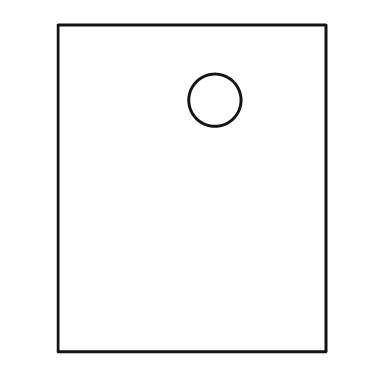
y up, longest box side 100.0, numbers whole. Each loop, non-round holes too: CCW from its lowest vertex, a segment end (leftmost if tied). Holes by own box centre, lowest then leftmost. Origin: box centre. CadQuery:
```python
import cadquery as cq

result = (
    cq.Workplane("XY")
    .moveTo(-41.0, -50.0)
    .lineTo(41.0, -50.0)
    .lineTo(41.0, 50.0)
    .lineTo(-41.0, 50.0)
    .close()
    .moveTo(7.0, 27.0)
    .circle(8.0)
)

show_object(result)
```